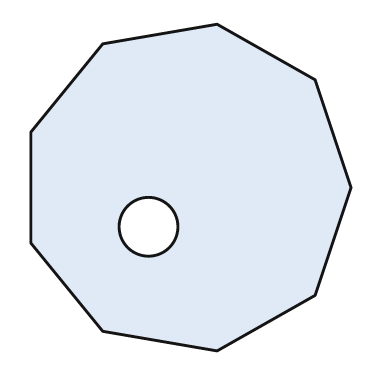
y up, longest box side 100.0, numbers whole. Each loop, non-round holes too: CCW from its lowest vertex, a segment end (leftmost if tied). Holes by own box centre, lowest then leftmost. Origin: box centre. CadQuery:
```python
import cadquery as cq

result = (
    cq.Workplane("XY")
    .moveTo(8.0, -50.0)
    .lineTo(38.0, -33.0)
    .lineTo(49.0, 0.0)
    .lineTo(38.0, 33.0)
    .lineTo(8.0, 50.0)
    .lineTo(-27.0, 44.0)
    .lineTo(-49.0, 17.0)
    .lineTo(-49.0, -17.0)
    .lineTo(-27.0, -44.0)
    .close()
    .moveTo(-13.0, -12.0)
    .circle(9.0)
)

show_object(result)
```